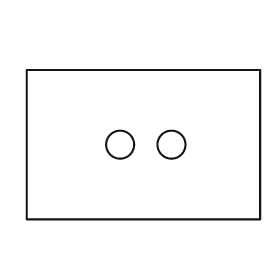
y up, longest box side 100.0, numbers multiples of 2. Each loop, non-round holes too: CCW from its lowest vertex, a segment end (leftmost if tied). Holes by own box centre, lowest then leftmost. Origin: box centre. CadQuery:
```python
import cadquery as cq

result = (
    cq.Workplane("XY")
    .moveTo(-50.0, -32.0)
    .lineTo(50.0, -32.0)
    .lineTo(50.0, 32.0)
    .lineTo(-50.0, 32.0)
    .close()
    .moveTo(-10.0, 0.0)
    .circle(6.0)
    .moveTo(12.0, 0.0)
    .circle(6.0)
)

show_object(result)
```